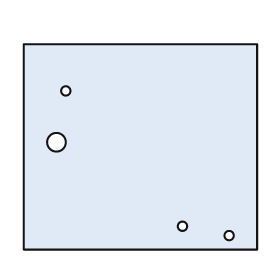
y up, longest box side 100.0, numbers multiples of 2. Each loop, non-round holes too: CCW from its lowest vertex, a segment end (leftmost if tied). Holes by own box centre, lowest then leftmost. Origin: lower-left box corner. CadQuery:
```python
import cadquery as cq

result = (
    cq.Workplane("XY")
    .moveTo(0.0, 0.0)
    .lineTo(100.0, 0.0)
    .lineTo(100.0, 88.0)
    .lineTo(0.0, 88.0)
    .close()
    .moveTo(88.0, 6.0)
    .circle(2.0)
    .moveTo(68.0, 10.0)
    .circle(2.0)
    .moveTo(14.0, 46.0)
    .circle(4.0)
    .moveTo(18.0, 68.0)
    .circle(2.0)
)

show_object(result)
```